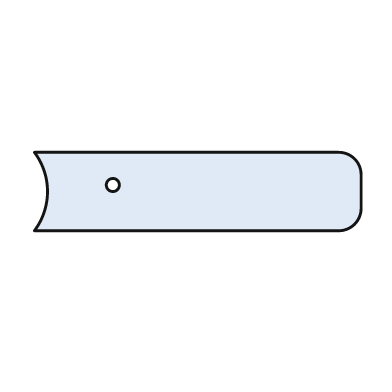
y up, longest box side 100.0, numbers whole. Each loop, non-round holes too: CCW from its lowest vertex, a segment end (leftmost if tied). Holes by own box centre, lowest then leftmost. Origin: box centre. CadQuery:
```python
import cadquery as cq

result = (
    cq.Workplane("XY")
    .moveTo(-50.0, -12.0)
    .lineTo(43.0, -12.0)
    .threePointArc((48.0, -10.0), (50.0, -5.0))
    .lineTo(50.0, 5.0)
    .threePointArc((48.0, 10.0), (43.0, 12.0))
    .lineTo(-50.0, 12.0)
    .threePointArc((-46.0, 0.0), (-50.0, -12.0))
    .close()
    .moveTo(-26.0, 2.0)
    .circle(2.0)
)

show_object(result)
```